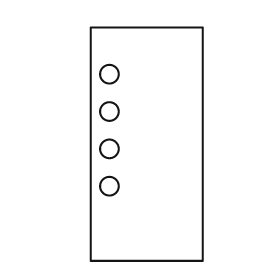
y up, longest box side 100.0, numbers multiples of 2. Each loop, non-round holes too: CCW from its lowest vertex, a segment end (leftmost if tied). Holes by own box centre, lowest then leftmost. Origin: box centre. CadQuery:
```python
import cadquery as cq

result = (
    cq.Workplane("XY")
    .moveTo(-24.0, -50.0)
    .lineTo(24.0, -50.0)
    .lineTo(24.0, 50.0)
    .lineTo(-24.0, 50.0)
    .close()
    .moveTo(-16.0, -18.0)
    .circle(4.0)
    .moveTo(-16.0, -2.0)
    .circle(4.0)
    .moveTo(-16.0, 14.0)
    .circle(4.0)
    .moveTo(-16.0, 30.0)
    .circle(4.0)
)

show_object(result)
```